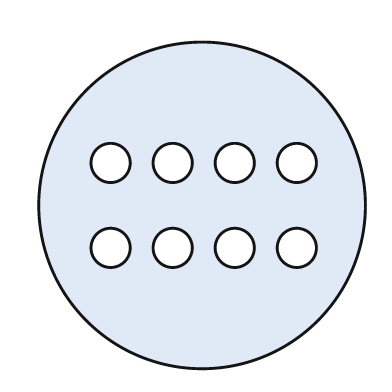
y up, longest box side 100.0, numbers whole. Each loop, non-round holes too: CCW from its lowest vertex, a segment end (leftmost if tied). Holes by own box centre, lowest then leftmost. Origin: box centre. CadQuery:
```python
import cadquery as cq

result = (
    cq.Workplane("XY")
    .moveTo(0.0, 0.0)
    .circle(50.0)
    .moveTo(-28.0, -13.0)
    .circle(6.0)
    .moveTo(-9.0, -13.0)
    .circle(6.0)
    .moveTo(10.0, -13.0)
    .circle(6.0)
    .moveTo(29.0, -13.0)
    .circle(6.0)
    .moveTo(-28.0, 13.0)
    .circle(6.0)
    .moveTo(-9.0, 13.0)
    .circle(6.0)
    .moveTo(10.0, 13.0)
    .circle(6.0)
    .moveTo(29.0, 13.0)
    .circle(6.0)
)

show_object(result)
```